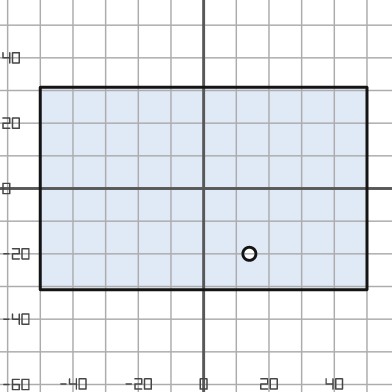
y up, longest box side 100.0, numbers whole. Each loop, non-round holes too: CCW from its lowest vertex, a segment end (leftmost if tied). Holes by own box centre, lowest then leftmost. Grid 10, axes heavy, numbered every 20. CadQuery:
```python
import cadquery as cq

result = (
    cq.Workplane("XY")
    .moveTo(-50.0, -31.0)
    .lineTo(50.0, -31.0)
    .lineTo(50.0, 31.0)
    .lineTo(-50.0, 31.0)
    .close()
    .moveTo(14.0, -20.0)
    .circle(2.0)
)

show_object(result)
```